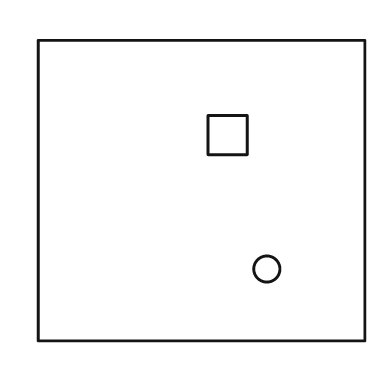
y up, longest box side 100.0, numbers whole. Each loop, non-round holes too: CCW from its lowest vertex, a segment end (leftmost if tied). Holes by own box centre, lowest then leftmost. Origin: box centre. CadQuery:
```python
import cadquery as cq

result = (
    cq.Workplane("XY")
    .moveTo(-50.0, -46.0)
    .lineTo(50.0, -46.0)
    .lineTo(50.0, 46.0)
    .lineTo(-50.0, 46.0)
    .close()
    .moveTo(20.0, -24.0)
    .circle(4.0)
    .moveTo(2.0, 11.0)
    .lineTo(14.0, 11.0)
    .lineTo(14.0, 23.0)
    .lineTo(2.0, 23.0)
    .close()
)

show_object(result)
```